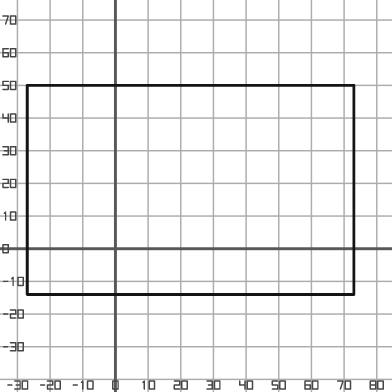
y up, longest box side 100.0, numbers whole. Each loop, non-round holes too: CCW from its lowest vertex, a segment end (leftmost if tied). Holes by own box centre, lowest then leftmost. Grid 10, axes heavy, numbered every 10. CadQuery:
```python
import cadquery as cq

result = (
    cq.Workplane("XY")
    .moveTo(-27.0, -14.0)
    .lineTo(73.0, -14.0)
    .lineTo(73.0, 50.0)
    .lineTo(-27.0, 50.0)
    .close()
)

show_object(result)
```